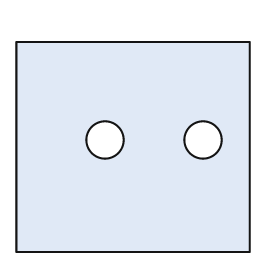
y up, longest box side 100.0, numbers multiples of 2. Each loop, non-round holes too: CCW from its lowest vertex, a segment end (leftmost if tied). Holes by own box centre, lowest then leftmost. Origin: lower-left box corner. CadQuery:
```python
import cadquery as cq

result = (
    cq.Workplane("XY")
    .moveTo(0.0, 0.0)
    .lineTo(100.0, 0.0)
    .lineTo(100.0, 90.0)
    .lineTo(0.0, 90.0)
    .close()
    .moveTo(38.0, 48.0)
    .circle(8.0)
    .moveTo(80.0, 48.0)
    .circle(8.0)
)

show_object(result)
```